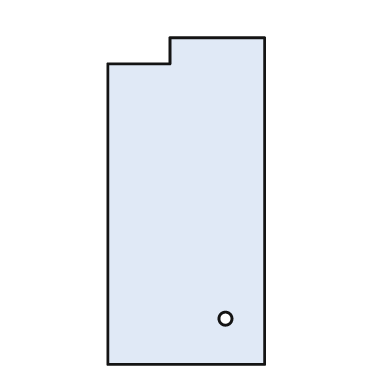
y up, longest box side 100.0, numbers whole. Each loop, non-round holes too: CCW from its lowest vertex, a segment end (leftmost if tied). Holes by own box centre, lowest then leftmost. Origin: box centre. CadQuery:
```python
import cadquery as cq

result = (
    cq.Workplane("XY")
    .moveTo(-24.0, -50.0)
    .lineTo(24.0, -50.0)
    .lineTo(24.0, 50.0)
    .lineTo(-5.0, 50.0)
    .lineTo(-5.0, 42.0)
    .lineTo(-24.0, 42.0)
    .close()
    .moveTo(12.0, -36.0)
    .circle(2.0)
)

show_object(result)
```